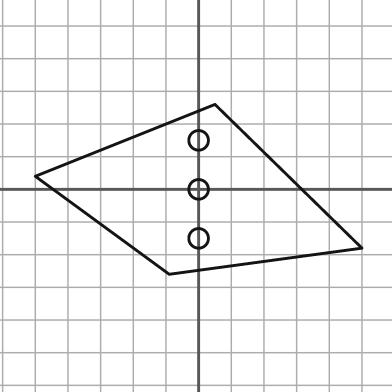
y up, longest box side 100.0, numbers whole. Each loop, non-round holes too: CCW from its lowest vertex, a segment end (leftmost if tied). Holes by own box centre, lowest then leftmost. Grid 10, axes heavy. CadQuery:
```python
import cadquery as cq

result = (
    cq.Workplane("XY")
    .moveTo(-9.0, -26.0)
    .lineTo(50.0, -18.0)
    .lineTo(5.0, 26.0)
    .lineTo(-50.0, 4.0)
    .close()
    .moveTo(0.0, -15.0)
    .circle(3.0)
    .moveTo(0.0, 0.0)
    .circle(3.0)
    .moveTo(0.0, 15.0)
    .circle(3.0)
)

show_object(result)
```